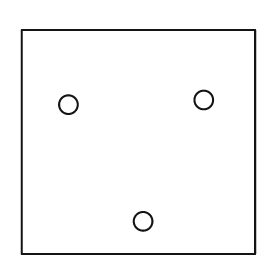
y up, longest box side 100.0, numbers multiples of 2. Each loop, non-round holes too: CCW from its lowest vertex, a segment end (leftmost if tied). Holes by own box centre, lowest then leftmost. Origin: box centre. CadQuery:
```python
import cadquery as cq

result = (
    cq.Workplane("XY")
    .moveTo(-50.0, -48.0)
    .lineTo(50.0, -48.0)
    .lineTo(50.0, 48.0)
    .lineTo(-50.0, 48.0)
    .close()
    .moveTo(2.0, -34.0)
    .circle(4.0)
    .moveTo(-30.0, 16.0)
    .circle(4.0)
    .moveTo(28.0, 18.0)
    .circle(4.0)
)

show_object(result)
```